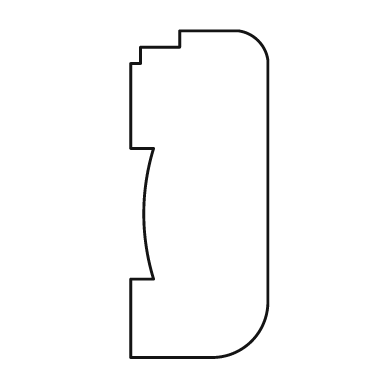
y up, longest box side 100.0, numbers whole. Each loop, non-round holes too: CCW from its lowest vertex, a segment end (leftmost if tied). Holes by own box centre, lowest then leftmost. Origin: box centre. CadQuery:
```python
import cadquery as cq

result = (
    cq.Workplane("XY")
    .moveTo(-21.0, -50.0)
    .lineTo(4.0, -50.0)
    .threePointArc((16.0, -45.0), (21.0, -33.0))
    .lineTo(21.0, 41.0)
    .threePointArc((18.0, 47.0), (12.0, 50.0))
    .lineTo(-6.0, 50.0)
    .lineTo(-6.0, 45.0)
    .lineTo(-18.0, 45.0)
    .lineTo(-18.0, 40.0)
    .lineTo(-21.0, 40.0)
    .lineTo(-21.0, 14.0)
    .lineTo(-14.0, 14.0)
    .threePointArc((-17.0, -6.0), (-14.0, -26.0))
    .lineTo(-21.0, -26.0)
    .close()
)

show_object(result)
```